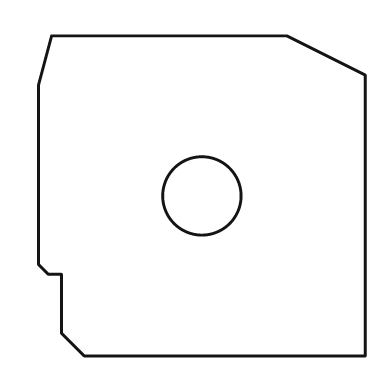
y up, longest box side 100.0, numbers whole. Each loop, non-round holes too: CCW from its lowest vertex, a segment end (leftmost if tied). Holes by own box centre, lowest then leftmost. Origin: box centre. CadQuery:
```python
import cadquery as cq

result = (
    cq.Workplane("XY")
    .moveTo(-36.0, -49.0)
    .lineTo(50.0, -49.0)
    .lineTo(50.0, 37.0)
    .lineTo(26.0, 49.0)
    .lineTo(-46.0, 49.0)
    .lineTo(-50.0, 34.0)
    .lineTo(-50.0, -21.0)
    .lineTo(-47.0, -24.0)
    .lineTo(-43.0, -24.0)
    .lineTo(-43.0, -42.0)
    .close()
    .moveTo(0.0, 0.0)
    .circle(12.0)
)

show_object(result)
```